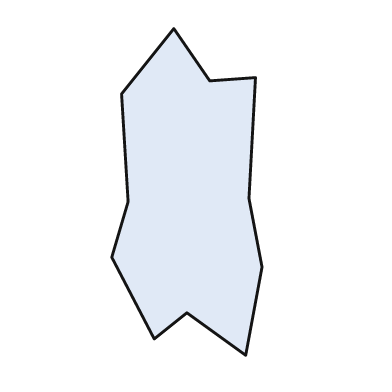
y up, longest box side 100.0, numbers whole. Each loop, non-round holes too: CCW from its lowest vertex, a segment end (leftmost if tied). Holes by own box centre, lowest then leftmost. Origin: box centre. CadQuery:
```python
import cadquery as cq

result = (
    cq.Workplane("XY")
    .moveTo(18.0, -50.0)
    .lineTo(23.0, -23.0)
    .lineTo(19.0, -2.0)
    .lineTo(21.0, 35.0)
    .lineTo(7.0, 34.0)
    .lineTo(-4.0, 50.0)
    .lineTo(-20.0, 30.0)
    .lineTo(-18.0, -3.0)
    .lineTo(-23.0, -20.0)
    .lineTo(-10.0, -45.0)
    .lineTo(0.0, -37.0)
    .close()
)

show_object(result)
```